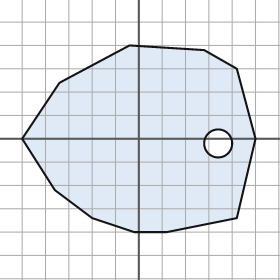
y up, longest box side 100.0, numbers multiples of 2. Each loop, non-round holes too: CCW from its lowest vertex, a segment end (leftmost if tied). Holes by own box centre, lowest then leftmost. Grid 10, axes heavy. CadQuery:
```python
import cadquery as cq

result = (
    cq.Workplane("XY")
    .moveTo(-2.0, -40.0)
    .lineTo(12.0, -40.0)
    .lineTo(42.0, -34.0)
    .lineTo(50.0, 0.0)
    .lineTo(42.0, 30.0)
    .lineTo(28.0, 38.0)
    .lineTo(-4.0, 40.0)
    .lineTo(-34.0, 24.0)
    .lineTo(-50.0, 0.0)
    .lineTo(-36.0, -22.0)
    .lineTo(-20.0, -34.0)
    .close()
    .moveTo(34.0, -2.0)
    .circle(6.0)
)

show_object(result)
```